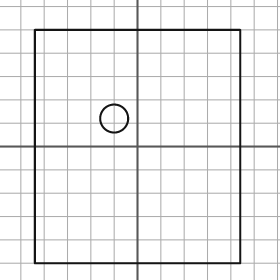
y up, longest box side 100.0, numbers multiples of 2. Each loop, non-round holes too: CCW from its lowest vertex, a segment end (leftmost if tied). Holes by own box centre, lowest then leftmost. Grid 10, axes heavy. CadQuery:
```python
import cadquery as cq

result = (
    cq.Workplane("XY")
    .moveTo(-44.0, -50.0)
    .lineTo(44.0, -50.0)
    .lineTo(44.0, 50.0)
    .lineTo(-44.0, 50.0)
    .close()
    .moveTo(-10.0, 12.0)
    .circle(6.0)
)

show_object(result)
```